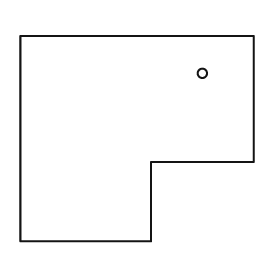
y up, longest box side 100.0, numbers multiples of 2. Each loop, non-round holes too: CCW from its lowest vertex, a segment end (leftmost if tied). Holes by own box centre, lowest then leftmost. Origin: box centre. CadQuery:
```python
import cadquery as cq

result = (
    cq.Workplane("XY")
    .moveTo(-50.0, -44.0)
    .lineTo(6.0, -44.0)
    .lineTo(6.0, -10.0)
    .lineTo(50.0, -10.0)
    .lineTo(50.0, 44.0)
    .lineTo(-50.0, 44.0)
    .close()
    .moveTo(28.0, 28.0)
    .circle(2.0)
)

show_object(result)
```